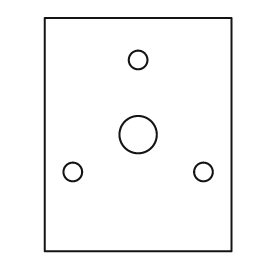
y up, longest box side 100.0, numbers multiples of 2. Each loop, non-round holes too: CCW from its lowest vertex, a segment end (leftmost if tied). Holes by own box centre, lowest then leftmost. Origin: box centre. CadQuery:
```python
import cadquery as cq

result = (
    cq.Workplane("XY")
    .moveTo(-40.0, -50.0)
    .lineTo(40.0, -50.0)
    .lineTo(40.0, 50.0)
    .lineTo(-40.0, 50.0)
    .close()
    .moveTo(-28.0, -16.0)
    .circle(4.0)
    .moveTo(28.0, -16.0)
    .circle(4.0)
    .moveTo(0.0, 0.0)
    .circle(8.0)
    .moveTo(0.0, 32.0)
    .circle(4.0)
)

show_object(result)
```